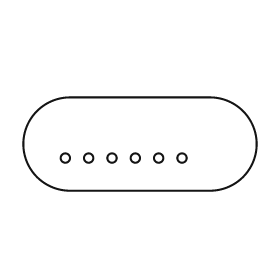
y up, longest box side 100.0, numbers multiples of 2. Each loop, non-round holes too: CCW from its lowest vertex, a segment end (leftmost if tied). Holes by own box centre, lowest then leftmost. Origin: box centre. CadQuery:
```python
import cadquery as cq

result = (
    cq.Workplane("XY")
    .moveTo(-30.0, -20.0)
    .lineTo(30.0, -20.0)
    .threePointArc((50.0, 0.0), (30.0, 20.0))
    .lineTo(-30.0, 20.0)
    .threePointArc((-50.0, 0.0), (-30.0, -20.0))
    .close()
    .moveTo(-32.0, -6.0)
    .circle(2.0)
    .moveTo(-22.0, -6.0)
    .circle(2.0)
    .moveTo(-12.0, -6.0)
    .circle(2.0)
    .moveTo(-2.0, -6.0)
    .circle(2.0)
    .moveTo(8.0, -6.0)
    .circle(2.0)
    .moveTo(18.0, -6.0)
    .circle(2.0)
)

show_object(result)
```